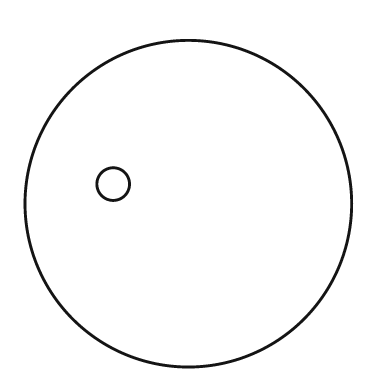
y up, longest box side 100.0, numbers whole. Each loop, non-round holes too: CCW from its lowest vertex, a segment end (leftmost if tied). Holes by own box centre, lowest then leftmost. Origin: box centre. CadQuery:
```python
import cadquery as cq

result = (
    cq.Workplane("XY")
    .moveTo(0.0, 0.0)
    .circle(50.0)
    .moveTo(-23.0, 6.0)
    .circle(5.0)
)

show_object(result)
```